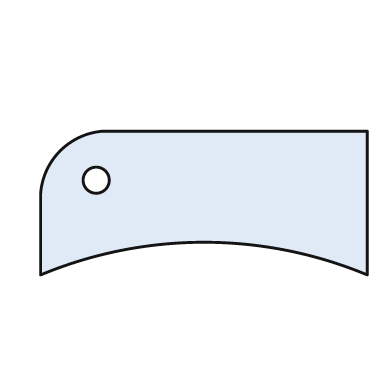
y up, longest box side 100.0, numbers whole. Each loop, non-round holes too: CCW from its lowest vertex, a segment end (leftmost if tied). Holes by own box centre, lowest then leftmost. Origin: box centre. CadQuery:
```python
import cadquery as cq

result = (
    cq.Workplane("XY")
    .moveTo(-50.0, -22.0)
    .threePointArc((0.0, -12.0), (50.0, -22.0))
    .lineTo(50.0, 22.0)
    .lineTo(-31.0, 22.0)
    .threePointArc((-44.0, 16.0), (-50.0, 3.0))
    .close()
    .moveTo(-33.0, 7.0)
    .circle(4.0)
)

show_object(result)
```